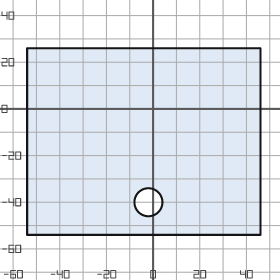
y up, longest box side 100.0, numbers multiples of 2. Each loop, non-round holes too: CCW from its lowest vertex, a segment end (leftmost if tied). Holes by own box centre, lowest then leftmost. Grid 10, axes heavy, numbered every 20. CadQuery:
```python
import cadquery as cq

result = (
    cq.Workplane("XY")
    .moveTo(-54.0, -54.0)
    .lineTo(46.0, -54.0)
    .lineTo(46.0, 26.0)
    .lineTo(-54.0, 26.0)
    .close()
    .moveTo(-2.0, -40.0)
    .circle(6.0)
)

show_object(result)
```